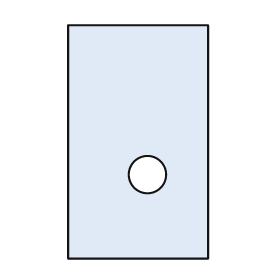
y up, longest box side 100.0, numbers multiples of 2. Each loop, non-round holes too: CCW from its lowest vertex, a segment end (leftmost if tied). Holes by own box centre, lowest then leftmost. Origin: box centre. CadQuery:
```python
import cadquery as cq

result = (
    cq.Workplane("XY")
    .moveTo(-30.0, -50.0)
    .lineTo(30.0, -50.0)
    .lineTo(30.0, 50.0)
    .lineTo(-30.0, 50.0)
    .close()
    .moveTo(4.0, -14.0)
    .circle(8.0)
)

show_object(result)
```